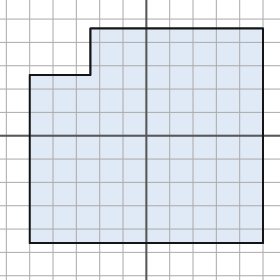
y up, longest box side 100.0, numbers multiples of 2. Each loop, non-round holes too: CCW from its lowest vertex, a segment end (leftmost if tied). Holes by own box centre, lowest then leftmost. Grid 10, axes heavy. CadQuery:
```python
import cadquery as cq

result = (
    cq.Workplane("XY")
    .moveTo(-50.0, -46.0)
    .lineTo(50.0, -46.0)
    .lineTo(50.0, 46.0)
    .lineTo(-24.0, 46.0)
    .lineTo(-24.0, 26.0)
    .lineTo(-50.0, 26.0)
    .close()
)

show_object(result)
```